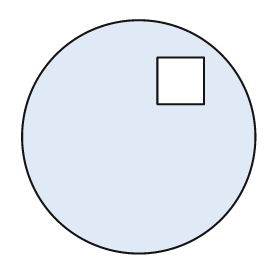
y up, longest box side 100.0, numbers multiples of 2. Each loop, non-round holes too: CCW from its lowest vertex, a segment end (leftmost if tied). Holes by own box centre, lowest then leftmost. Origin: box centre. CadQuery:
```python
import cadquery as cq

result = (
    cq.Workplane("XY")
    .moveTo(0.0, 0.0)
    .circle(50.0)
    .moveTo(8.0, 14.0)
    .lineTo(28.0, 14.0)
    .lineTo(28.0, 34.0)
    .lineTo(8.0, 34.0)
    .close()
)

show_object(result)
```